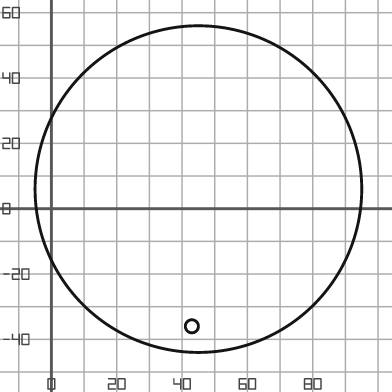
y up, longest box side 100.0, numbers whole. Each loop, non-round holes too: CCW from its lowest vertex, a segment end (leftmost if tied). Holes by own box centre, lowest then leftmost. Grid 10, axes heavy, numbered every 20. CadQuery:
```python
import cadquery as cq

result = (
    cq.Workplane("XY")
    .moveTo(45.0, 6.0)
    .circle(50.0)
    .moveTo(43.0, -36.0)
    .circle(2.0)
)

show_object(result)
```